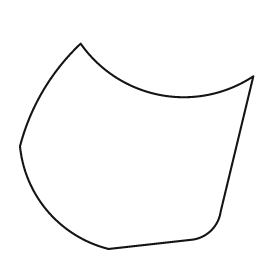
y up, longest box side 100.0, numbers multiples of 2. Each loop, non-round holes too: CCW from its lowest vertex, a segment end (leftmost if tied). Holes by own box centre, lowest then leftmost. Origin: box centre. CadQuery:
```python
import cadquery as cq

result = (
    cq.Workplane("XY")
    .moveTo(-12.0, -44.0)
    .lineTo(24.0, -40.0)
    .threePointArc((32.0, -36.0), (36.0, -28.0))
    .lineTo(50.0, 30.0)
    .threePointArc((10.0, 22.0), (-24.0, 44.0))
    .threePointArc((-40.0, 24.0), (-50.0, 0.0))
    .threePointArc((-38.0, -28.0), (-12.0, -44.0))
    .close()
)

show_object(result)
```